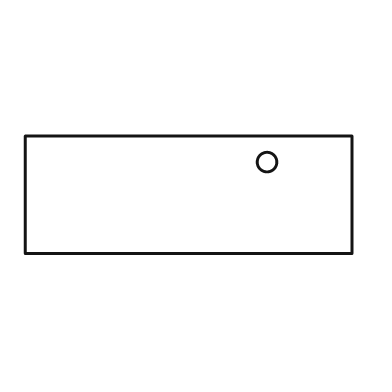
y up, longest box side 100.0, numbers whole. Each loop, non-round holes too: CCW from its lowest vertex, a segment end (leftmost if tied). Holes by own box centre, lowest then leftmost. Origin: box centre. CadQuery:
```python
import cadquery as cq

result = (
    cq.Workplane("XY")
    .moveTo(-50.0, -18.0)
    .lineTo(50.0, -18.0)
    .lineTo(50.0, 18.0)
    .lineTo(-50.0, 18.0)
    .close()
    .moveTo(24.0, 10.0)
    .circle(3.0)
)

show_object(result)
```